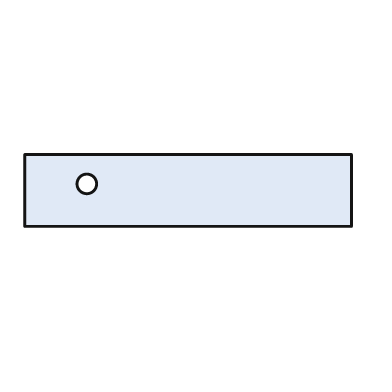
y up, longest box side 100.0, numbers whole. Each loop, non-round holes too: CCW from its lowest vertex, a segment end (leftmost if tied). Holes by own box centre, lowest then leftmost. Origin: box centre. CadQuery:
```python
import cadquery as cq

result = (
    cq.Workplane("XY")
    .moveTo(-50.0, -11.0)
    .lineTo(50.0, -11.0)
    .lineTo(50.0, 11.0)
    .lineTo(-50.0, 11.0)
    .close()
    .moveTo(-31.0, 2.0)
    .circle(3.0)
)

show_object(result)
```